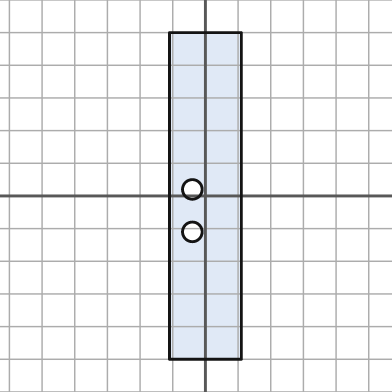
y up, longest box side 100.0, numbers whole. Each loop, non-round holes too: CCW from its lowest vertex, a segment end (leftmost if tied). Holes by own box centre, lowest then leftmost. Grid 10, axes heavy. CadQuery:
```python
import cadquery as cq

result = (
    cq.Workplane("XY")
    .moveTo(-11.0, -50.0)
    .lineTo(11.0, -50.0)
    .lineTo(11.0, 50.0)
    .lineTo(-11.0, 50.0)
    .close()
    .moveTo(-4.0, -11.0)
    .circle(3.0)
    .moveTo(-4.0, 2.0)
    .circle(3.0)
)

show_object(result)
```